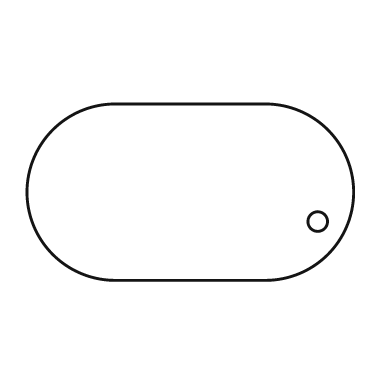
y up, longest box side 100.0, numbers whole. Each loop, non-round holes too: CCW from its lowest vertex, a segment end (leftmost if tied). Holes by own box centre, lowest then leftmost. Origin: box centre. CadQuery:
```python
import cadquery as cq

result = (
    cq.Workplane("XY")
    .moveTo(-23.0, -27.0)
    .lineTo(23.0, -27.0)
    .threePointArc((50.0, 0.0), (23.0, 27.0))
    .lineTo(-23.0, 27.0)
    .threePointArc((-50.0, 0.0), (-23.0, -27.0))
    .close()
    .moveTo(39.0, -9.0)
    .circle(3.0)
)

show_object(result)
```